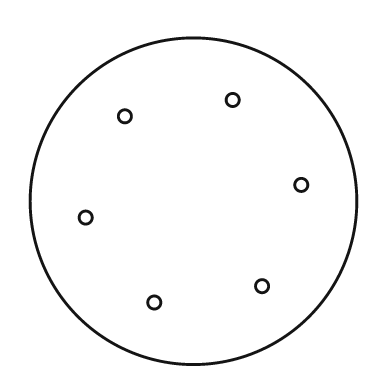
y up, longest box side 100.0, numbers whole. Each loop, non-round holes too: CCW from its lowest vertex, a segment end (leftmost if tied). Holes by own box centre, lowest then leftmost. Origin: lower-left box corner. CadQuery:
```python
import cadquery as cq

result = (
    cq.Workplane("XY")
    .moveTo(50.0, 50.0)
    .circle(50.0)
    .moveTo(38.0, 19.0)
    .circle(2.0)
    .moveTo(71.0, 24.0)
    .circle(2.0)
    .moveTo(17.0, 45.0)
    .circle(2.0)
    .moveTo(83.0, 55.0)
    .circle(2.0)
    .moveTo(29.0, 76.0)
    .circle(2.0)
    .moveTo(62.0, 81.0)
    .circle(2.0)
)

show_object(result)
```